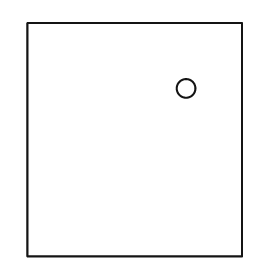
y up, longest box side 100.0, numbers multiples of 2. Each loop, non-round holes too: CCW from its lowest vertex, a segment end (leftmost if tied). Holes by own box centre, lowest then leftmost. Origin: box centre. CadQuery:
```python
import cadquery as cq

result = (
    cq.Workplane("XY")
    .moveTo(-46.0, -50.0)
    .lineTo(46.0, -50.0)
    .lineTo(46.0, 50.0)
    .lineTo(-46.0, 50.0)
    .close()
    .moveTo(22.0, 22.0)
    .circle(4.0)
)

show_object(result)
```